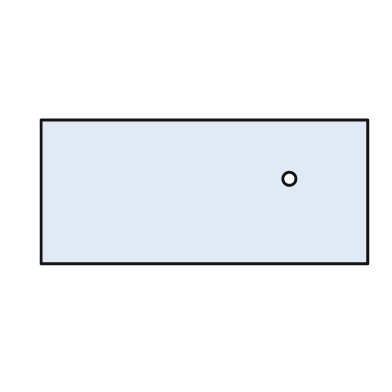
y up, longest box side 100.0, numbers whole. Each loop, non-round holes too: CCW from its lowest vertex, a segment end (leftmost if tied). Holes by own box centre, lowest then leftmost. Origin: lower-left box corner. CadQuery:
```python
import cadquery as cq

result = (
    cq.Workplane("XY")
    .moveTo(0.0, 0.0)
    .lineTo(100.0, 0.0)
    .lineTo(100.0, 44.0)
    .lineTo(0.0, 44.0)
    .close()
    .moveTo(76.0, 26.0)
    .circle(2.0)
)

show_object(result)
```